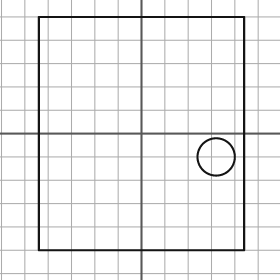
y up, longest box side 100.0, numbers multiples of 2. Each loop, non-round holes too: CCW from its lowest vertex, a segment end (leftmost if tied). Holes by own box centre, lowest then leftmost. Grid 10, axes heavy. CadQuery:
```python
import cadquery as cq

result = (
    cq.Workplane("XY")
    .moveTo(-44.0, -50.0)
    .lineTo(44.0, -50.0)
    .lineTo(44.0, 50.0)
    .lineTo(-44.0, 50.0)
    .close()
    .moveTo(32.0, -10.0)
    .circle(8.0)
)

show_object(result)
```